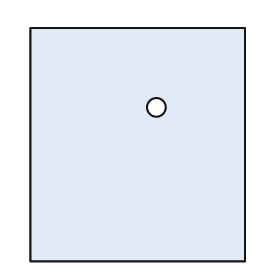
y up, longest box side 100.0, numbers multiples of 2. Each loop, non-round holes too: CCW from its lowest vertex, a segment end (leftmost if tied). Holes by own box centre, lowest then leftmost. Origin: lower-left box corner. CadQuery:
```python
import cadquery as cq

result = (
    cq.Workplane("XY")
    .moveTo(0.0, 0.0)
    .lineTo(92.0, 0.0)
    .lineTo(92.0, 100.0)
    .lineTo(0.0, 100.0)
    .close()
    .moveTo(54.0, 66.0)
    .circle(4.0)
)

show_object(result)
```